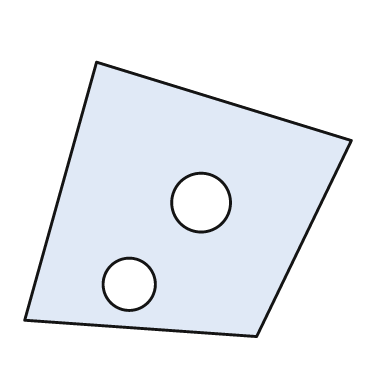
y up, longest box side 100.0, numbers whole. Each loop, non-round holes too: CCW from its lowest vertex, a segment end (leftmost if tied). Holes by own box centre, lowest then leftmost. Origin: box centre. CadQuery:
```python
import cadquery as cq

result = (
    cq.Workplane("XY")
    .moveTo(21.0, -42.0)
    .lineTo(50.0, 18.0)
    .lineTo(-28.0, 42.0)
    .lineTo(-50.0, -37.0)
    .close()
    .moveTo(-18.0, -26.0)
    .circle(8.0)
    .moveTo(4.0, -1.0)
    .circle(9.0)
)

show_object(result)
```